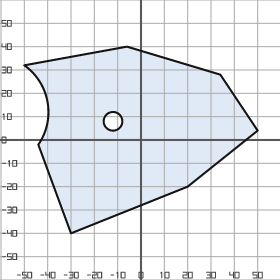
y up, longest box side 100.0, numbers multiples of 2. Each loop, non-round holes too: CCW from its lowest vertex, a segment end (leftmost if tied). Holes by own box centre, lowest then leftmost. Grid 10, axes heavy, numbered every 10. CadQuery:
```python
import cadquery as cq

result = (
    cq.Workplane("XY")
    .moveTo(-30.0, -40.0)
    .lineTo(20.0, -20.0)
    .lineTo(50.0, 4.0)
    .lineTo(34.0, 28.0)
    .lineTo(-6.0, 40.0)
    .lineTo(-50.0, 32.0)
    .threePointArc((-40.0, 16.0), (-44.0, -2.0))
    .close()
    .moveTo(-12.0, 8.0)
    .circle(4.0)
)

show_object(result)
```